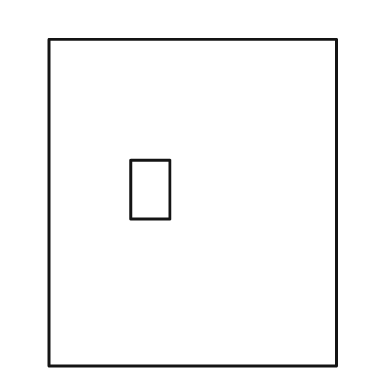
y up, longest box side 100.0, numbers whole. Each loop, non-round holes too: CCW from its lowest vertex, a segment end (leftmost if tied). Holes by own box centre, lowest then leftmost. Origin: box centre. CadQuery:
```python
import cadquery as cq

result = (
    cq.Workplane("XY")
    .moveTo(-44.0, -50.0)
    .lineTo(44.0, -50.0)
    .lineTo(44.0, 50.0)
    .lineTo(-44.0, 50.0)
    .close()
    .moveTo(-19.0, -5.0)
    .lineTo(-7.0, -5.0)
    .lineTo(-7.0, 13.0)
    .lineTo(-19.0, 13.0)
    .close()
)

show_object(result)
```